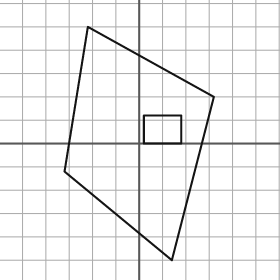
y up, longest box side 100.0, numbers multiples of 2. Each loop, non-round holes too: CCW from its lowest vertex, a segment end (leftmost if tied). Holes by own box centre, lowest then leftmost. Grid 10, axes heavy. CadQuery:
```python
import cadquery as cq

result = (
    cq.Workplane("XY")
    .moveTo(14.0, -50.0)
    .lineTo(32.0, 20.0)
    .lineTo(-22.0, 50.0)
    .lineTo(-32.0, -12.0)
    .close()
    .moveTo(2.0, 0.0)
    .lineTo(18.0, 0.0)
    .lineTo(18.0, 12.0)
    .lineTo(2.0, 12.0)
    .close()
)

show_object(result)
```